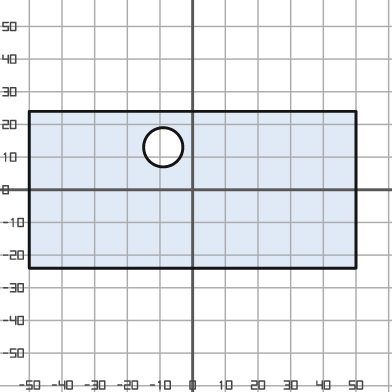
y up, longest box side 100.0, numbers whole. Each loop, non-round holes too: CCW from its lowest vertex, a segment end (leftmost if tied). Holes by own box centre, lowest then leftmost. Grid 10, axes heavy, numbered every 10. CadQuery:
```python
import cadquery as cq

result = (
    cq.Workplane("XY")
    .moveTo(-50.0, -24.0)
    .lineTo(50.0, -24.0)
    .lineTo(50.0, 24.0)
    .lineTo(-50.0, 24.0)
    .close()
    .moveTo(-9.0, 13.0)
    .circle(6.0)
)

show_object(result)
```